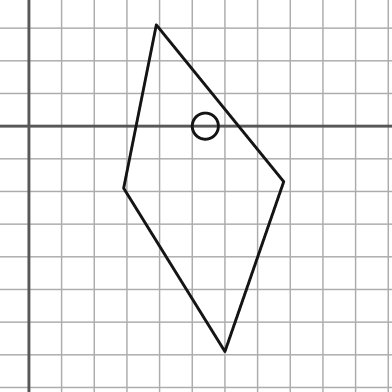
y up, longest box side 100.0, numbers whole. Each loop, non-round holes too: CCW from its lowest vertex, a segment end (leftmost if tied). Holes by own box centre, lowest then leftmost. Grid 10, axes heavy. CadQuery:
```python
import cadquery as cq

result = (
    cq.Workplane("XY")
    .moveTo(60.0, -69.0)
    .lineTo(78.0, -17.0)
    .lineTo(39.0, 31.0)
    .lineTo(29.0, -19.0)
    .close()
    .moveTo(54.0, 0.0)
    .circle(4.0)
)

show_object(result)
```